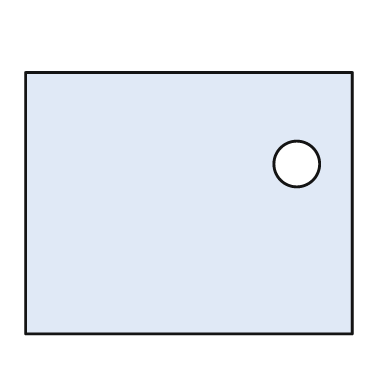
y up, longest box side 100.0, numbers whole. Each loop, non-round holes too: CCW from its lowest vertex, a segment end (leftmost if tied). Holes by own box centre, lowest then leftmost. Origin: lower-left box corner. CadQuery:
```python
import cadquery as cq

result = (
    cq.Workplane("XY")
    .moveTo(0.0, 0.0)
    .lineTo(100.0, 0.0)
    .lineTo(100.0, 80.0)
    .lineTo(0.0, 80.0)
    .close()
    .moveTo(83.0, 52.0)
    .circle(7.0)
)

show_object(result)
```